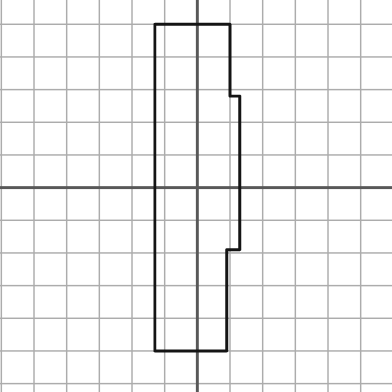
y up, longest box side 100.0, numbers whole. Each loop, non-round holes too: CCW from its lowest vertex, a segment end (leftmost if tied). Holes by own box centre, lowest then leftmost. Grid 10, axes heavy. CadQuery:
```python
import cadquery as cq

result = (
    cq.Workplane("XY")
    .moveTo(-13.0, -50.0)
    .lineTo(9.0, -50.0)
    .lineTo(9.0, -19.0)
    .lineTo(13.0, -19.0)
    .lineTo(13.0, 28.0)
    .lineTo(10.0, 28.0)
    .lineTo(10.0, 50.0)
    .lineTo(-13.0, 50.0)
    .close()
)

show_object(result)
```